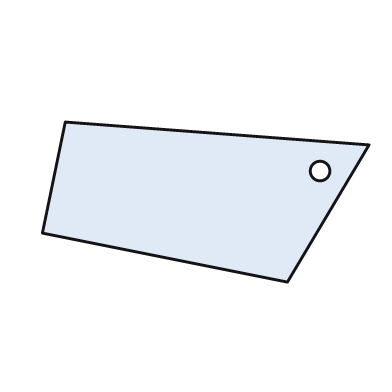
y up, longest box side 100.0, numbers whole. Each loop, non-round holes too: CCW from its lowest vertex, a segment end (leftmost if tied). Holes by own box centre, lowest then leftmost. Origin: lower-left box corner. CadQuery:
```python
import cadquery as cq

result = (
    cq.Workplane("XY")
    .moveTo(75.0, 0.0)
    .lineTo(100.0, 42.0)
    .lineTo(7.0, 49.0)
    .lineTo(0.0, 15.0)
    .close()
    .moveTo(85.0, 34.0)
    .circle(3.0)
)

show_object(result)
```